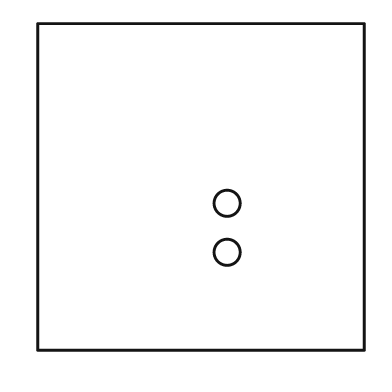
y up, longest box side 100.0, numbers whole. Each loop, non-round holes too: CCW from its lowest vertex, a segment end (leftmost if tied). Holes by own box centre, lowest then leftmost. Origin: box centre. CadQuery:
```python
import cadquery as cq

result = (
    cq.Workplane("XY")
    .moveTo(-50.0, -50.0)
    .lineTo(50.0, -50.0)
    .lineTo(50.0, 50.0)
    .lineTo(-50.0, 50.0)
    .close()
    .moveTo(8.0, -20.0)
    .circle(4.0)
    .moveTo(8.0, -5.0)
    .circle(4.0)
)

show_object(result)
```